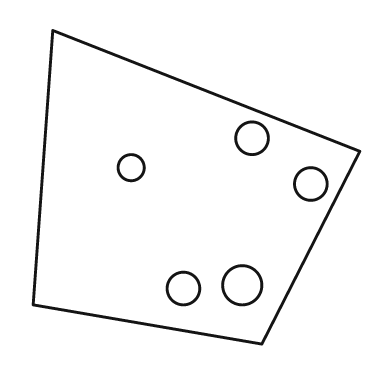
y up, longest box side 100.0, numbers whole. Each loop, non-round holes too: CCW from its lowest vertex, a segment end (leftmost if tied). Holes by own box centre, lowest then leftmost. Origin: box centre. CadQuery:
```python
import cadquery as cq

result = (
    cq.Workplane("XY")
    .moveTo(20.0, -48.0)
    .lineTo(50.0, 11.0)
    .lineTo(-44.0, 48.0)
    .lineTo(-50.0, -36.0)
    .close()
    .moveTo(-4.0, -31.0)
    .circle(5.0)
    .moveTo(14.0, -30.0)
    .circle(6.0)
    .moveTo(35.0, 1.0)
    .circle(5.0)
    .moveTo(-20.0, 6.0)
    .circle(4.0)
    .moveTo(17.0, 15.0)
    .circle(5.0)
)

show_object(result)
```